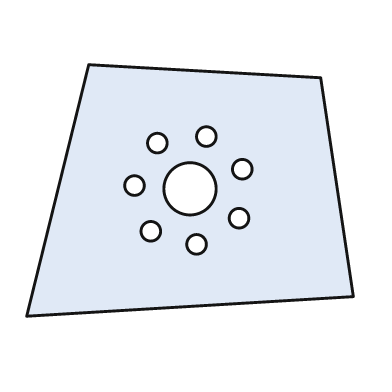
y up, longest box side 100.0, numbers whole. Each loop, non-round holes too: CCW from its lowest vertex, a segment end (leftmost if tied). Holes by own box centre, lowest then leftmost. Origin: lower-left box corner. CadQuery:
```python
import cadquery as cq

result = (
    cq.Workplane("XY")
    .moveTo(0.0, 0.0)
    .lineTo(100.0, 6.0)
    .lineTo(90.0, 73.0)
    .lineTo(19.0, 77.0)
    .close()
    .moveTo(52.0, 22.0)
    .circle(3.0)
    .moveTo(38.0, 26.0)
    .circle(3.0)
    .moveTo(65.0, 30.0)
    .circle(3.0)
    .moveTo(50.0, 39.0)
    .circle(8.0)
    .moveTo(33.0, 40.0)
    .circle(3.0)
    .moveTo(66.0, 45.0)
    .circle(3.0)
    .moveTo(40.0, 53.0)
    .circle(3.0)
    .moveTo(55.0, 55.0)
    .circle(3.0)
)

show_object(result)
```